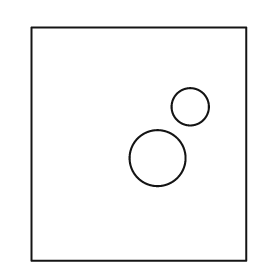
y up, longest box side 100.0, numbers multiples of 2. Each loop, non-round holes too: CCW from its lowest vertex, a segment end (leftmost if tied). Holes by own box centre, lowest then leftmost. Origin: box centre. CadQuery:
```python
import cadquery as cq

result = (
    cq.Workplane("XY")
    .moveTo(-46.0, -50.0)
    .lineTo(46.0, -50.0)
    .lineTo(46.0, 50.0)
    .lineTo(-46.0, 50.0)
    .close()
    .moveTo(8.0, -6.0)
    .circle(12.0)
    .moveTo(22.0, 16.0)
    .circle(8.0)
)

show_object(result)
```